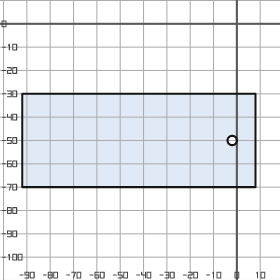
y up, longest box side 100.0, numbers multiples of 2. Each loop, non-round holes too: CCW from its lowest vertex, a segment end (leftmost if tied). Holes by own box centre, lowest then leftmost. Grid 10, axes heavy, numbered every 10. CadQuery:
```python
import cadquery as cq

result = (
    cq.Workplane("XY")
    .moveTo(-92.0, -70.0)
    .lineTo(8.0, -70.0)
    .lineTo(8.0, -30.0)
    .lineTo(-92.0, -30.0)
    .close()
    .moveTo(-2.0, -50.0)
    .circle(2.0)
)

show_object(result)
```